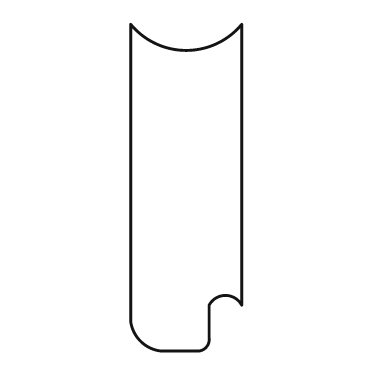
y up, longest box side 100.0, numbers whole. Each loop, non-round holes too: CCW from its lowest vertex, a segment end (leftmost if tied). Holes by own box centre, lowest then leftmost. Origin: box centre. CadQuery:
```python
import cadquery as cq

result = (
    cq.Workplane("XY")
    .moveTo(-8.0, -50.0)
    .lineTo(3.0, -50.0)
    .threePointArc((6.0, -49.0), (7.0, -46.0))
    .lineTo(7.0, -36.0)
    .threePointArc((12.0, -33.0), (17.0, -36.0))
    .lineTo(17.0, 50.0)
    .threePointArc((0.0, 42.0), (-17.0, 50.0))
    .lineTo(-17.0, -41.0)
    .threePointArc((-14.0, -47.0), (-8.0, -50.0))
    .close()
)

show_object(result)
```